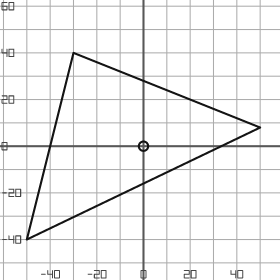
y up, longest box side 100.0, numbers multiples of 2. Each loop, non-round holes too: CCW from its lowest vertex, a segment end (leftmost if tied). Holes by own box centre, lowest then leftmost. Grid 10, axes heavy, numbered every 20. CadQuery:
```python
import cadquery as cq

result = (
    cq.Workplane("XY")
    .moveTo(-50.0, -40.0)
    .lineTo(50.0, 8.0)
    .lineTo(-30.0, 40.0)
    .close()
    .moveTo(0.0, 0.0)
    .circle(2.0)
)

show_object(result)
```